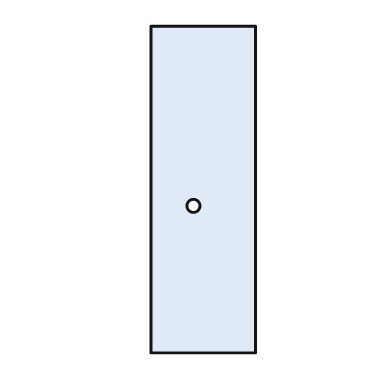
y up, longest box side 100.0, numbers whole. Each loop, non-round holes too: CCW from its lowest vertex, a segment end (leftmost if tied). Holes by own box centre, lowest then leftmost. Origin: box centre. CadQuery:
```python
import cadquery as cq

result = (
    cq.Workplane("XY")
    .moveTo(-16.0, -50.0)
    .lineTo(16.0, -50.0)
    .lineTo(16.0, 50.0)
    .lineTo(-16.0, 50.0)
    .close()
    .moveTo(-3.0, -5.0)
    .circle(2.0)
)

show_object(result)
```